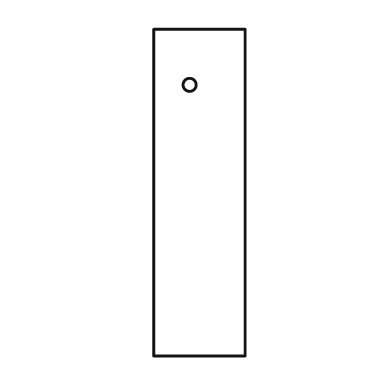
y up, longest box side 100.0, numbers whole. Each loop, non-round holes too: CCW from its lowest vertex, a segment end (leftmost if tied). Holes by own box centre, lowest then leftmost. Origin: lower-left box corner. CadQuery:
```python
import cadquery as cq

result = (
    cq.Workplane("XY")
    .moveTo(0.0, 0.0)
    .lineTo(28.0, 0.0)
    .lineTo(28.0, 100.0)
    .lineTo(0.0, 100.0)
    .close()
    .moveTo(11.0, 83.0)
    .circle(2.0)
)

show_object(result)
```